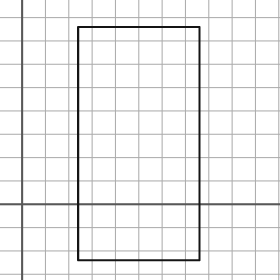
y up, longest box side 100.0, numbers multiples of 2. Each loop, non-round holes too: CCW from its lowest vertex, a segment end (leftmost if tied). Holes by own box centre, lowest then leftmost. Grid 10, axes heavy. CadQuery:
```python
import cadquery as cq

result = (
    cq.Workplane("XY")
    .moveTo(24.0, -24.0)
    .lineTo(76.0, -24.0)
    .lineTo(76.0, 76.0)
    .lineTo(24.0, 76.0)
    .close()
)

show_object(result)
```